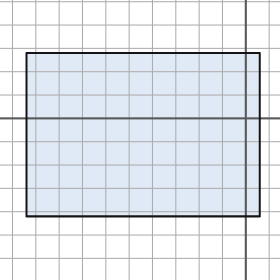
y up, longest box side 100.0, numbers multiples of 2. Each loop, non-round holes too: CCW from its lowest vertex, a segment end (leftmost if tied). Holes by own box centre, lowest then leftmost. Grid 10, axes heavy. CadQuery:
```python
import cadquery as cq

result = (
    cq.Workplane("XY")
    .moveTo(-94.0, -42.0)
    .lineTo(6.0, -42.0)
    .lineTo(6.0, 28.0)
    .lineTo(-94.0, 28.0)
    .close()
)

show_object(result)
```